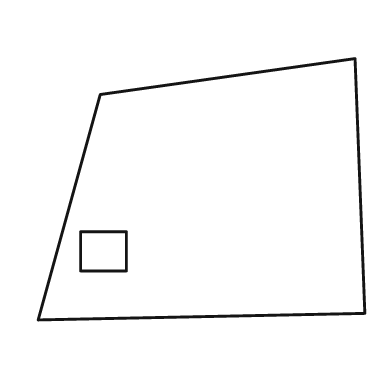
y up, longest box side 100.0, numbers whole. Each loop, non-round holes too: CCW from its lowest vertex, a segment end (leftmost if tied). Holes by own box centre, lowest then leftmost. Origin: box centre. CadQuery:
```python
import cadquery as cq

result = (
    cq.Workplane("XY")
    .moveTo(-50.0, -40.0)
    .lineTo(50.0, -38.0)
    .lineTo(47.0, 40.0)
    .lineTo(-31.0, 29.0)
    .close()
    .moveTo(-37.0, -25.0)
    .lineTo(-23.0, -25.0)
    .lineTo(-23.0, -13.0)
    .lineTo(-37.0, -13.0)
    .close()
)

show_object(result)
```